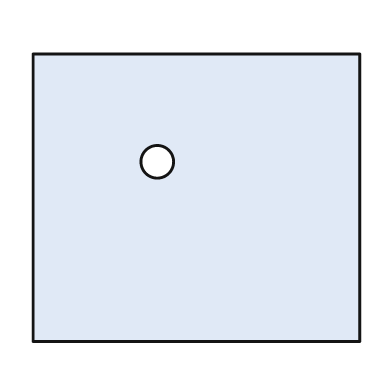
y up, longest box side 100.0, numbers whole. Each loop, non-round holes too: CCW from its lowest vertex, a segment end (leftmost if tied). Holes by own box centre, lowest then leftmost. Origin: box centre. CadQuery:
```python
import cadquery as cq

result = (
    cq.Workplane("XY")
    .moveTo(-50.0, -44.0)
    .lineTo(50.0, -44.0)
    .lineTo(50.0, 44.0)
    .lineTo(-50.0, 44.0)
    .close()
    .moveTo(-12.0, 11.0)
    .circle(5.0)
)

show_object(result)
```